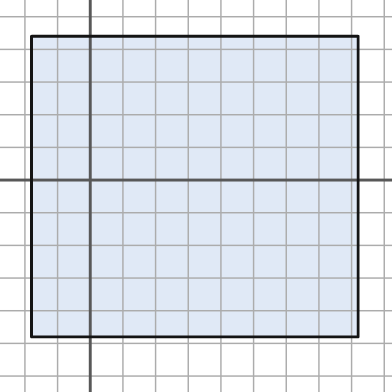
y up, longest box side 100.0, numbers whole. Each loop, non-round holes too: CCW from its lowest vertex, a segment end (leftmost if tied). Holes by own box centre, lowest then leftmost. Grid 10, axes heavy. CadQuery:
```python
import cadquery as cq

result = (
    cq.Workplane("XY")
    .moveTo(-18.0, -48.0)
    .lineTo(82.0, -48.0)
    .lineTo(82.0, 44.0)
    .lineTo(-18.0, 44.0)
    .close()
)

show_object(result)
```